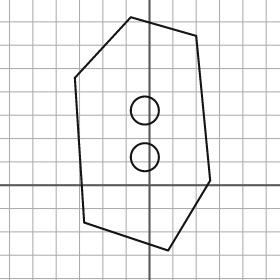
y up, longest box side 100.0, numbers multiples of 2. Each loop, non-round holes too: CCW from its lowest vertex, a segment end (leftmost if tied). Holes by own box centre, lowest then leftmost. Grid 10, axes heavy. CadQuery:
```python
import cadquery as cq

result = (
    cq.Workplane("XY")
    .moveTo(8.0, -28.0)
    .lineTo(26.0, 2.0)
    .lineTo(20.0, 64.0)
    .lineTo(-8.0, 72.0)
    .lineTo(-32.0, 46.0)
    .lineTo(-28.0, -16.0)
    .close()
    .moveTo(-2.0, 12.0)
    .circle(6.0)
    .moveTo(-2.0, 32.0)
    .circle(6.0)
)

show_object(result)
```